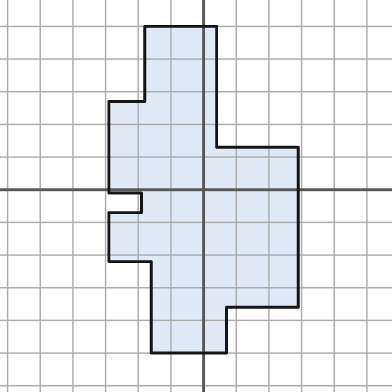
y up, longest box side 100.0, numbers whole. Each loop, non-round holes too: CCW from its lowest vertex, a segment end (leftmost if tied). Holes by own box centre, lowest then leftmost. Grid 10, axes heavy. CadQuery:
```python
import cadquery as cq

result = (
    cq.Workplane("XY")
    .moveTo(-16.0, -50.0)
    .lineTo(7.0, -50.0)
    .lineTo(7.0, -36.0)
    .lineTo(29.0, -36.0)
    .lineTo(29.0, 13.0)
    .lineTo(4.0, 13.0)
    .lineTo(4.0, 50.0)
    .lineTo(-18.0, 50.0)
    .lineTo(-18.0, 27.0)
    .lineTo(-29.0, 27.0)
    .lineTo(-29.0, -1.0)
    .lineTo(-19.0, -1.0)
    .lineTo(-19.0, -7.0)
    .lineTo(-29.0, -7.0)
    .lineTo(-29.0, -22.0)
    .lineTo(-16.0, -22.0)
    .close()
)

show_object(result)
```